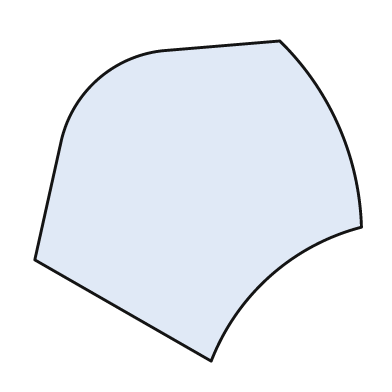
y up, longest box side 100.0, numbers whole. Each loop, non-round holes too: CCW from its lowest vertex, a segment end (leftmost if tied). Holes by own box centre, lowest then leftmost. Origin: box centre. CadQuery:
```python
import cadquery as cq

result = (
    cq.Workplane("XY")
    .moveTo(4.0, -49.0)
    .threePointArc((22.0, -23.0), (50.0, -8.0))
    .threePointArc((43.0, 23.0), (25.0, 49.0))
    .lineTo(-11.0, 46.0)
    .threePointArc((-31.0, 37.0), (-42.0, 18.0))
    .lineTo(-50.0, -18.0)
    .close()
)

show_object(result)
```